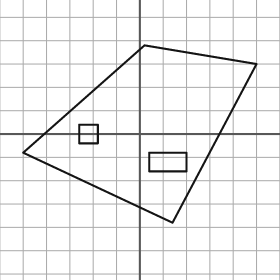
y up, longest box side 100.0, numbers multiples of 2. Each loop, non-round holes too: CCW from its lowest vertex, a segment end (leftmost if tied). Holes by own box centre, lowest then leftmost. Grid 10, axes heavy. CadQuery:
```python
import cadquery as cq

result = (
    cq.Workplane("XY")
    .moveTo(14.0, -38.0)
    .lineTo(50.0, 30.0)
    .lineTo(2.0, 38.0)
    .lineTo(-50.0, -8.0)
    .close()
    .moveTo(4.0, -16.0)
    .lineTo(20.0, -16.0)
    .lineTo(20.0, -8.0)
    .lineTo(4.0, -8.0)
    .close()
    .moveTo(-26.0, -4.0)
    .lineTo(-18.0, -4.0)
    .lineTo(-18.0, 4.0)
    .lineTo(-26.0, 4.0)
    .close()
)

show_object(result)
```